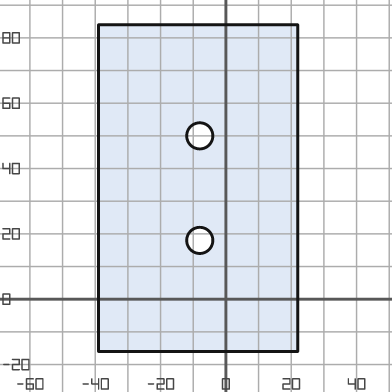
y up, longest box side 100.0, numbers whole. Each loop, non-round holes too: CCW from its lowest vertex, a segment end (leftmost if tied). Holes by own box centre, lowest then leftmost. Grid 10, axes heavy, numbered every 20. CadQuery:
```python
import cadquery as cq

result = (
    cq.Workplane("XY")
    .moveTo(-39.0, -16.0)
    .lineTo(22.0, -16.0)
    .lineTo(22.0, 84.0)
    .lineTo(-39.0, 84.0)
    .close()
    .moveTo(-8.0, 18.0)
    .circle(4.0)
    .moveTo(-8.0, 50.0)
    .circle(4.0)
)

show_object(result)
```